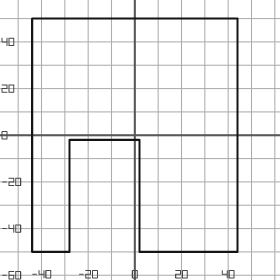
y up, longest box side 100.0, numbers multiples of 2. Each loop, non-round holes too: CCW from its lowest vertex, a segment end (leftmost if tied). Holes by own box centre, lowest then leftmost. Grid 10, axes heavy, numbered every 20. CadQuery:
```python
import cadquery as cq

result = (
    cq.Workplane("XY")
    .moveTo(-44.0, -50.0)
    .lineTo(-28.0, -50.0)
    .lineTo(-28.0, -2.0)
    .lineTo(2.0, -2.0)
    .lineTo(2.0, -50.0)
    .lineTo(44.0, -50.0)
    .lineTo(44.0, 50.0)
    .lineTo(-44.0, 50.0)
    .close()
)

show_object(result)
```